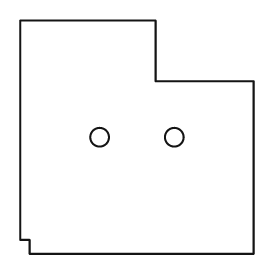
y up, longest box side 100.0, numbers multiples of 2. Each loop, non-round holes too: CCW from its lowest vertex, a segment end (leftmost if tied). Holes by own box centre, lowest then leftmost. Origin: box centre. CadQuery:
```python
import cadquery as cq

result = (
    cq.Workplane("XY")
    .moveTo(-46.0, -50.0)
    .lineTo(50.0, -50.0)
    .lineTo(50.0, 24.0)
    .lineTo(8.0, 24.0)
    .lineTo(8.0, 50.0)
    .lineTo(-50.0, 50.0)
    .lineTo(-50.0, -44.0)
    .lineTo(-46.0, -44.0)
    .close()
    .moveTo(-16.0, 0.0)
    .circle(4.0)
    .moveTo(16.0, 0.0)
    .circle(4.0)
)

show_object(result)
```